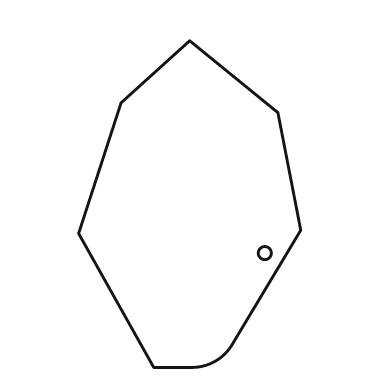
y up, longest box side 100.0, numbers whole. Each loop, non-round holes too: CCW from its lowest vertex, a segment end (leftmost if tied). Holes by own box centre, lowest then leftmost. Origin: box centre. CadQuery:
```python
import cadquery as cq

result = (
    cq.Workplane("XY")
    .moveTo(-11.0, -50.0)
    .lineTo(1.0, -50.0)
    .threePointArc((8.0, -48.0), (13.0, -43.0))
    .lineTo(34.0, -8.0)
    .lineTo(27.0, 28.0)
    .lineTo(0.0, 50.0)
    .lineTo(-21.0, 31.0)
    .lineTo(-34.0, -9.0)
    .close()
    .moveTo(23.0, -15.0)
    .circle(2.0)
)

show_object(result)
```